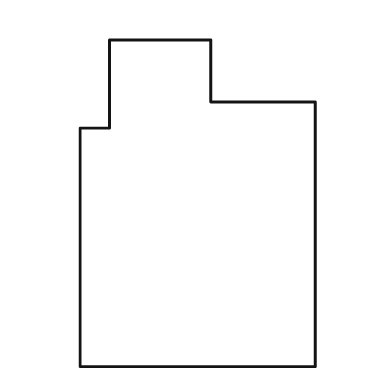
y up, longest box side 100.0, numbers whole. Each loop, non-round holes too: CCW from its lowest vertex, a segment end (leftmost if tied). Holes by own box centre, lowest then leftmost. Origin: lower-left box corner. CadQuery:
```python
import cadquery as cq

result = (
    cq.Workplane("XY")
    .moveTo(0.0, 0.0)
    .lineTo(72.0, 0.0)
    .lineTo(72.0, 81.0)
    .lineTo(40.0, 81.0)
    .lineTo(40.0, 100.0)
    .lineTo(9.0, 100.0)
    .lineTo(9.0, 73.0)
    .lineTo(0.0, 73.0)
    .close()
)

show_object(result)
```